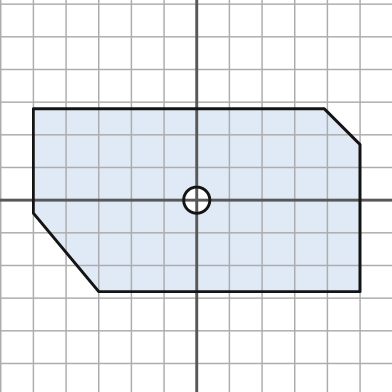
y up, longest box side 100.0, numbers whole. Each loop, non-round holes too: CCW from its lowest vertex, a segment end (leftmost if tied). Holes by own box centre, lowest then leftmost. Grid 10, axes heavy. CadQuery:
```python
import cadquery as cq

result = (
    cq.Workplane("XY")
    .moveTo(-30.0, -28.0)
    .lineTo(50.0, -28.0)
    .lineTo(50.0, 17.0)
    .lineTo(39.0, 28.0)
    .lineTo(-50.0, 28.0)
    .lineTo(-50.0, -4.0)
    .close()
    .moveTo(0.0, 0.0)
    .circle(4.0)
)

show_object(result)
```